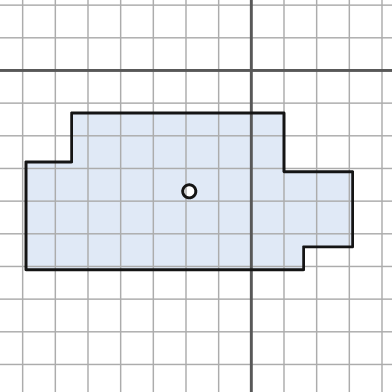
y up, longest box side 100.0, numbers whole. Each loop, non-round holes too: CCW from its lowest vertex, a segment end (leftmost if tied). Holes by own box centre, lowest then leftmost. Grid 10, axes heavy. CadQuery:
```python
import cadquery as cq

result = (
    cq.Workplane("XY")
    .moveTo(-69.0, -61.0)
    .lineTo(16.0, -61.0)
    .lineTo(16.0, -54.0)
    .lineTo(31.0, -54.0)
    .lineTo(31.0, -31.0)
    .lineTo(10.0, -31.0)
    .lineTo(10.0, -13.0)
    .lineTo(-55.0, -13.0)
    .lineTo(-55.0, -28.0)
    .lineTo(-69.0, -28.0)
    .close()
    .moveTo(-19.0, -37.0)
    .circle(2.0)
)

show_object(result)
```